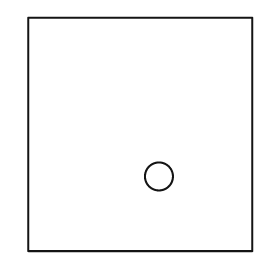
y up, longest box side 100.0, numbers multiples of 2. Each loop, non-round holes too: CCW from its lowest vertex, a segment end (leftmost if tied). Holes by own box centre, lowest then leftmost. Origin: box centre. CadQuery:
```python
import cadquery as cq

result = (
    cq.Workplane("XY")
    .moveTo(-48.0, -50.0)
    .lineTo(48.0, -50.0)
    .lineTo(48.0, 50.0)
    .lineTo(-48.0, 50.0)
    .close()
    .moveTo(8.0, -18.0)
    .circle(6.0)
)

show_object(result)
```